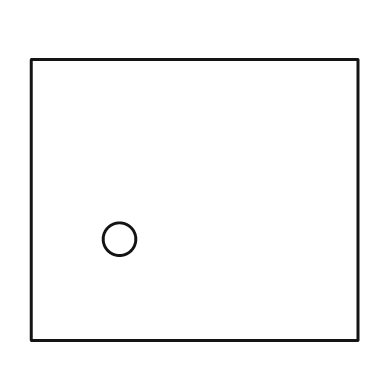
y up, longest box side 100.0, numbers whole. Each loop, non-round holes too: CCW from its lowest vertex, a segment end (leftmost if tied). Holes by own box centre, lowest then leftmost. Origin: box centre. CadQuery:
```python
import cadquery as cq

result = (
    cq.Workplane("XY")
    .moveTo(-50.0, -43.0)
    .lineTo(50.0, -43.0)
    .lineTo(50.0, 43.0)
    .lineTo(-50.0, 43.0)
    .close()
    .moveTo(-23.0, -12.0)
    .circle(5.0)
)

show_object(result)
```